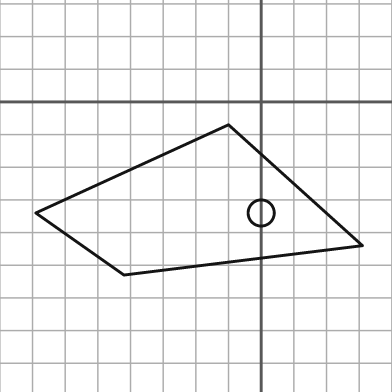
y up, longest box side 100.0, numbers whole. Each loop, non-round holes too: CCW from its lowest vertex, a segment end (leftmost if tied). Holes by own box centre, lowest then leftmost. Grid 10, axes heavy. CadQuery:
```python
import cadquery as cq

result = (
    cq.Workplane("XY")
    .moveTo(-42.0, -53.0)
    .lineTo(31.0, -44.0)
    .lineTo(-10.0, -7.0)
    .lineTo(-69.0, -34.0)
    .close()
    .moveTo(0.0, -34.0)
    .circle(4.0)
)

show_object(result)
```